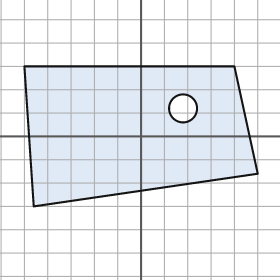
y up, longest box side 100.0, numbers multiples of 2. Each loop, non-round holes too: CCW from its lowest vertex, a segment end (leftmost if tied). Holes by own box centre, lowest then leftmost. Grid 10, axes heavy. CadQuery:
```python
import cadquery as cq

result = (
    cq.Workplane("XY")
    .moveTo(-46.0, -30.0)
    .lineTo(50.0, -16.0)
    .lineTo(40.0, 30.0)
    .lineTo(-50.0, 30.0)
    .close()
    .moveTo(18.0, 12.0)
    .circle(6.0)
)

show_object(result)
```